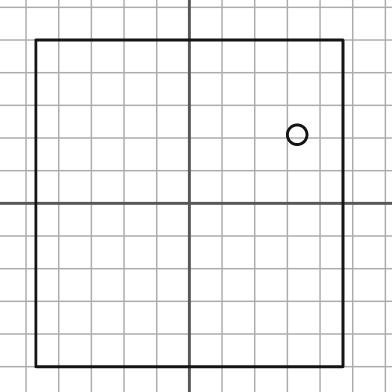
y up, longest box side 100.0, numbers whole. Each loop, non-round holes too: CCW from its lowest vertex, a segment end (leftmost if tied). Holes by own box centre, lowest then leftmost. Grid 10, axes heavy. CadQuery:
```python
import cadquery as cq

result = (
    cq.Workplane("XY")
    .moveTo(-47.0, -50.0)
    .lineTo(47.0, -50.0)
    .lineTo(47.0, 50.0)
    .lineTo(-47.0, 50.0)
    .close()
    .moveTo(33.0, 21.0)
    .circle(3.0)
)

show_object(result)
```